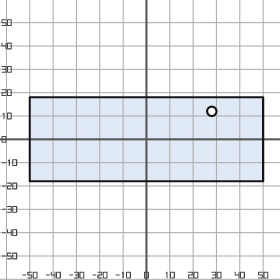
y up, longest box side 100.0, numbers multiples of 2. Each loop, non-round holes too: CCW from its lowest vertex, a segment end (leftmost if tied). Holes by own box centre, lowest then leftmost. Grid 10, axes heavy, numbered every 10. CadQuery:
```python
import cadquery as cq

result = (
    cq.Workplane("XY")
    .moveTo(-50.0, -18.0)
    .lineTo(50.0, -18.0)
    .lineTo(50.0, 18.0)
    .lineTo(-50.0, 18.0)
    .close()
    .moveTo(28.0, 12.0)
    .circle(2.0)
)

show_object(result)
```